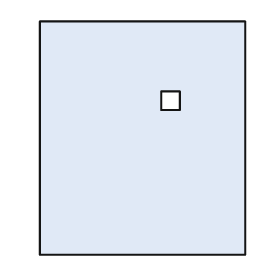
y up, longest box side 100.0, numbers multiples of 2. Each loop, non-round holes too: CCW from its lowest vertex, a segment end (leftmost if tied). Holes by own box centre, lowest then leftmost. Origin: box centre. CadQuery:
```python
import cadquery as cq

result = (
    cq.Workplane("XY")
    .moveTo(-44.0, -50.0)
    .lineTo(44.0, -50.0)
    .lineTo(44.0, 50.0)
    .lineTo(-44.0, 50.0)
    .close()
    .moveTo(8.0, 12.0)
    .lineTo(16.0, 12.0)
    .lineTo(16.0, 20.0)
    .lineTo(8.0, 20.0)
    .close()
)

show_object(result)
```